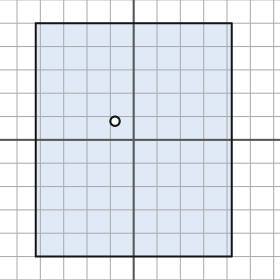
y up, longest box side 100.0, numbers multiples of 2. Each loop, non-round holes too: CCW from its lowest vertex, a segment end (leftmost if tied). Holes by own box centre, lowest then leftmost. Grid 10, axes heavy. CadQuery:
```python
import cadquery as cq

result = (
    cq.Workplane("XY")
    .moveTo(-42.0, -50.0)
    .lineTo(42.0, -50.0)
    .lineTo(42.0, 50.0)
    .lineTo(-42.0, 50.0)
    .close()
    .moveTo(-8.0, 8.0)
    .circle(2.0)
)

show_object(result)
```